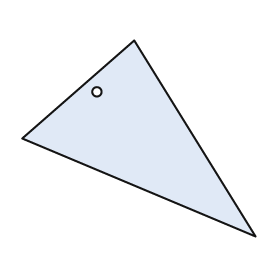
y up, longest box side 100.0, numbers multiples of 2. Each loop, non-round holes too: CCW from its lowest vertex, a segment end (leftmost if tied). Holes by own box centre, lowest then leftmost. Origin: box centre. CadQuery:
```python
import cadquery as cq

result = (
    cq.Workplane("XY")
    .moveTo(50.0, -42.0)
    .lineTo(-2.0, 42.0)
    .lineTo(-50.0, 0.0)
    .close()
    .moveTo(-18.0, 20.0)
    .circle(2.0)
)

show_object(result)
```